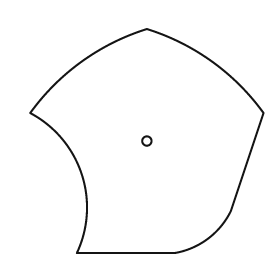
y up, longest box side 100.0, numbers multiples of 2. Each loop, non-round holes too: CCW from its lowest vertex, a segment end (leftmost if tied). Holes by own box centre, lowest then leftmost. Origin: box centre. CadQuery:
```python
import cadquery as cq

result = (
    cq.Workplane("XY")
    .moveTo(-30.0, -48.0)
    .lineTo(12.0, -48.0)
    .threePointArc((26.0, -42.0), (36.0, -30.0))
    .lineTo(50.0, 12.0)
    .threePointArc((28.0, 34.0), (0.0, 48.0))
    .threePointArc((-28.0, 34.0), (-50.0, 12.0))
    .threePointArc((-28.0, -14.0), (-30.0, -48.0))
    .close()
    .moveTo(0.0, 0.0)
    .circle(2.0)
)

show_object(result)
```